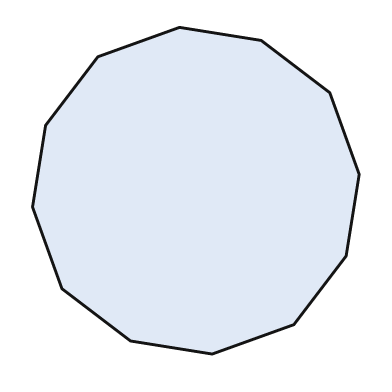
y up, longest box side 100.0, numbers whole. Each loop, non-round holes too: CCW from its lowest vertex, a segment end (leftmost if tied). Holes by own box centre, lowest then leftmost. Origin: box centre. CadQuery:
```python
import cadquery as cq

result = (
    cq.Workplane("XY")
    .moveTo(5.0, -50.0)
    .lineTo(30.0, -41.0)
    .lineTo(46.0, -20.0)
    .lineTo(50.0, 5.0)
    .lineTo(41.0, 30.0)
    .lineTo(20.0, 46.0)
    .lineTo(-5.0, 50.0)
    .lineTo(-30.0, 41.0)
    .lineTo(-46.0, 20.0)
    .lineTo(-50.0, -5.0)
    .lineTo(-41.0, -30.0)
    .lineTo(-20.0, -46.0)
    .close()
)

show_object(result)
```